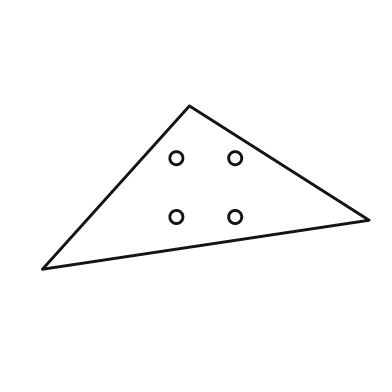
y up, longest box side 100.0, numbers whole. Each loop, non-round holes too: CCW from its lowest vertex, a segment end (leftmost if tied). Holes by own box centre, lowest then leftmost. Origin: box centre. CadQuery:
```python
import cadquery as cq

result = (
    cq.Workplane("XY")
    .moveTo(-50.0, -25.0)
    .lineTo(50.0, -10.0)
    .lineTo(-5.0, 25.0)
    .close()
    .moveTo(-9.0, -9.0)
    .circle(2.0)
    .moveTo(9.0, -9.0)
    .circle(2.0)
    .moveTo(-9.0, 9.0)
    .circle(2.0)
    .moveTo(9.0, 9.0)
    .circle(2.0)
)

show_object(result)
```